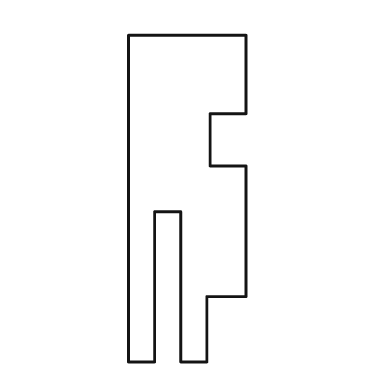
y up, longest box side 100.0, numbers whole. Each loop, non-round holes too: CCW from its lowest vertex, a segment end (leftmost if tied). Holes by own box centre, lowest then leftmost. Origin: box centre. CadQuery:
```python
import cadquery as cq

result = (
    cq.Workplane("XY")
    .moveTo(-18.0, -50.0)
    .lineTo(-10.0, -50.0)
    .lineTo(-10.0, -4.0)
    .lineTo(-2.0, -4.0)
    .lineTo(-2.0, -50.0)
    .lineTo(6.0, -50.0)
    .lineTo(6.0, -30.0)
    .lineTo(18.0, -30.0)
    .lineTo(18.0, 10.0)
    .lineTo(7.0, 10.0)
    .lineTo(7.0, 26.0)
    .lineTo(18.0, 26.0)
    .lineTo(18.0, 50.0)
    .lineTo(-18.0, 50.0)
    .close()
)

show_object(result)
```